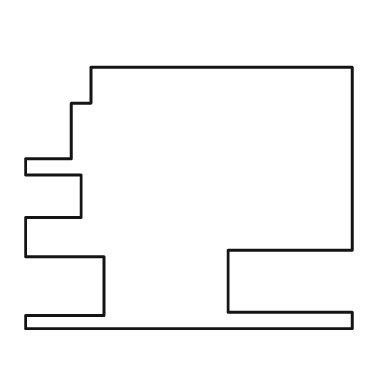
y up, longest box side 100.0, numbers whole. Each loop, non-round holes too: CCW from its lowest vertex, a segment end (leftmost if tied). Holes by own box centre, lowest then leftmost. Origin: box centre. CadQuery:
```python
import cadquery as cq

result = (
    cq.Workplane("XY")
    .moveTo(-50.0, -40.0)
    .lineTo(50.0, -40.0)
    .lineTo(50.0, -35.0)
    .lineTo(12.0, -35.0)
    .lineTo(12.0, -16.0)
    .lineTo(50.0, -16.0)
    .lineTo(50.0, 40.0)
    .lineTo(-30.0, 40.0)
    .lineTo(-30.0, 29.0)
    .lineTo(-36.0, 29.0)
    .lineTo(-36.0, 12.0)
    .lineTo(-50.0, 12.0)
    .lineTo(-50.0, 7.0)
    .lineTo(-33.0, 7.0)
    .lineTo(-33.0, -6.0)
    .lineTo(-50.0, -6.0)
    .lineTo(-50.0, -18.0)
    .lineTo(-26.0, -18.0)
    .lineTo(-26.0, -36.0)
    .lineTo(-50.0, -36.0)
    .close()
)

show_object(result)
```